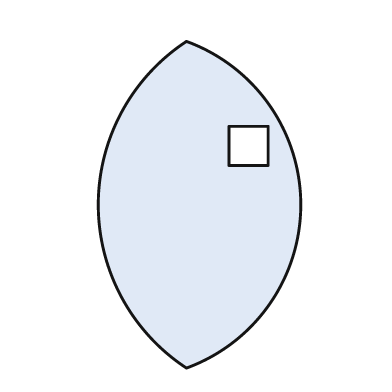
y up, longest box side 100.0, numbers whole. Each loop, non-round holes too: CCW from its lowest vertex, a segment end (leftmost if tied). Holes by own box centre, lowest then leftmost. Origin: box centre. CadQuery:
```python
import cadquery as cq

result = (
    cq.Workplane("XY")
    .moveTo(-4.0, -50.0)
    .threePointArc((31.0, 0.0), (-4.0, 50.0))
    .threePointArc((-31.0, 0.0), (-4.0, -50.0))
    .close()
    .moveTo(9.0, 12.0)
    .lineTo(21.0, 12.0)
    .lineTo(21.0, 24.0)
    .lineTo(9.0, 24.0)
    .close()
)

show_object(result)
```